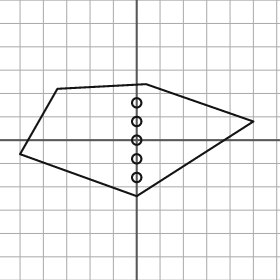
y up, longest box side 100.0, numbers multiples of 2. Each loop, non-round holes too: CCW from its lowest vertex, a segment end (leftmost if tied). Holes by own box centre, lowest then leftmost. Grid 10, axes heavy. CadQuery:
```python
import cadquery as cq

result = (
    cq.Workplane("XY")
    .moveTo(0.0, -24.0)
    .lineTo(50.0, 8.0)
    .lineTo(4.0, 24.0)
    .lineTo(-34.0, 22.0)
    .lineTo(-50.0, -6.0)
    .close()
    .moveTo(0.0, -16.0)
    .circle(2.0)
    .moveTo(0.0, -8.0)
    .circle(2.0)
    .moveTo(0.0, 0.0)
    .circle(2.0)
    .moveTo(0.0, 8.0)
    .circle(2.0)
    .moveTo(0.0, 16.0)
    .circle(2.0)
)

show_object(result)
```